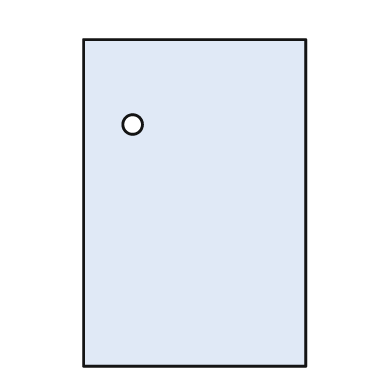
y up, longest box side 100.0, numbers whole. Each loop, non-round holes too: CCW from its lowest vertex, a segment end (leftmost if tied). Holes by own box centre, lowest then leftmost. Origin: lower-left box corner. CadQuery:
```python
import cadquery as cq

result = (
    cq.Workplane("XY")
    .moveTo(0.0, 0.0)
    .lineTo(68.0, 0.0)
    .lineTo(68.0, 100.0)
    .lineTo(0.0, 100.0)
    .close()
    .moveTo(15.0, 74.0)
    .circle(3.0)
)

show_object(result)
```